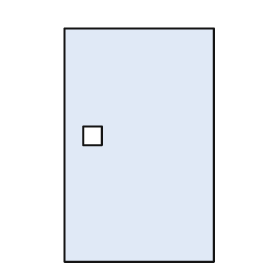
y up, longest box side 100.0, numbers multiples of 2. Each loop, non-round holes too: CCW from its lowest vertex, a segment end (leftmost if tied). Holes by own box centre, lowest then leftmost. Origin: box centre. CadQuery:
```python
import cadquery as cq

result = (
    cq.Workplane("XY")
    .moveTo(-32.0, -50.0)
    .lineTo(32.0, -50.0)
    .lineTo(32.0, 50.0)
    .lineTo(-32.0, 50.0)
    .close()
    .moveTo(-24.0, 0.0)
    .lineTo(-16.0, 0.0)
    .lineTo(-16.0, 8.0)
    .lineTo(-24.0, 8.0)
    .close()
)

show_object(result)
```